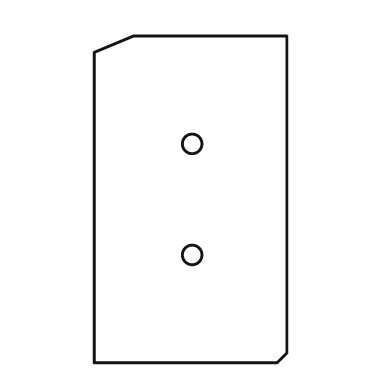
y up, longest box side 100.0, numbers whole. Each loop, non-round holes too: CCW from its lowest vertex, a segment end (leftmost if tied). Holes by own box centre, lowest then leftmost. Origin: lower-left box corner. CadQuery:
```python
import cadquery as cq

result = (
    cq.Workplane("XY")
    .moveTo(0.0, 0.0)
    .lineTo(56.0, 0.0)
    .lineTo(59.0, 3.0)
    .lineTo(59.0, 100.0)
    .lineTo(12.0, 100.0)
    .lineTo(0.0, 95.0)
    .close()
    .moveTo(30.0, 33.0)
    .circle(3.0)
    .moveTo(30.0, 67.0)
    .circle(3.0)
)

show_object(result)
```